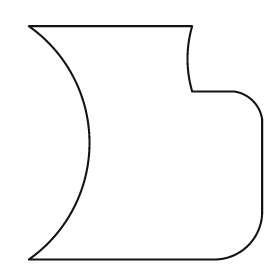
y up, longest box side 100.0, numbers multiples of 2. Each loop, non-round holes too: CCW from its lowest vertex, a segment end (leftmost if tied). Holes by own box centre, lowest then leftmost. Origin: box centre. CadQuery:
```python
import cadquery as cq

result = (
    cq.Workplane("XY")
    .moveTo(-50.0, -50.0)
    .lineTo(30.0, -50.0)
    .threePointArc((44.0, -44.0), (50.0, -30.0))
    .lineTo(50.0, 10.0)
    .threePointArc((46.0, 18.0), (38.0, 22.0))
    .lineTo(20.0, 22.0)
    .threePointArc((18.0, 36.0), (20.0, 50.0))
    .lineTo(-50.0, 50.0)
    .threePointArc((-24.0, 0.0), (-50.0, -50.0))
    .close()
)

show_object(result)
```